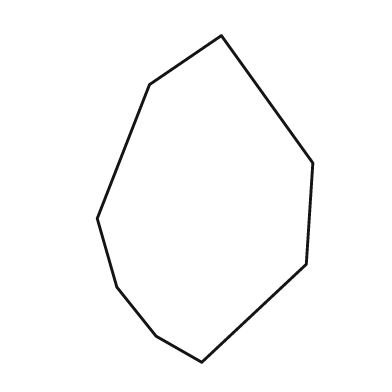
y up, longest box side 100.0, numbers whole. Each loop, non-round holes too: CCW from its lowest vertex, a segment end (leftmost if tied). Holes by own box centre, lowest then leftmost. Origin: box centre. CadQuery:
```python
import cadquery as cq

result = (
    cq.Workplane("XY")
    .moveTo(-1.0, -50.0)
    .lineTo(31.0, -20.0)
    .lineTo(33.0, 11.0)
    .lineTo(5.0, 50.0)
    .lineTo(-17.0, 35.0)
    .lineTo(-33.0, -6.0)
    .lineTo(-27.0, -27.0)
    .lineTo(-15.0, -42.0)
    .close()
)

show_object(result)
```